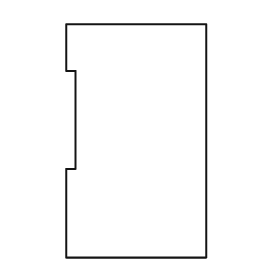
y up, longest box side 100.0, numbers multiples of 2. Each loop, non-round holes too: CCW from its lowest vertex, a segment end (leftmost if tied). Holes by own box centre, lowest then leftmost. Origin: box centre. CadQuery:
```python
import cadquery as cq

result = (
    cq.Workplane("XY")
    .moveTo(-30.0, -50.0)
    .lineTo(30.0, -50.0)
    .lineTo(30.0, 50.0)
    .lineTo(-30.0, 50.0)
    .lineTo(-30.0, 30.0)
    .lineTo(-26.0, 30.0)
    .lineTo(-26.0, -12.0)
    .lineTo(-30.0, -12.0)
    .close()
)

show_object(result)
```